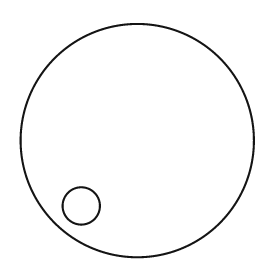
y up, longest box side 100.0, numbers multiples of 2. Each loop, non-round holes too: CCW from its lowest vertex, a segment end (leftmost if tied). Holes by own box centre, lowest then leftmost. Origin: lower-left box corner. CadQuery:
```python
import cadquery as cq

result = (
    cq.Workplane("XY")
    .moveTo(50.0, 50.0)
    .circle(50.0)
    .moveTo(26.0, 22.0)
    .circle(8.0)
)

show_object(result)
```